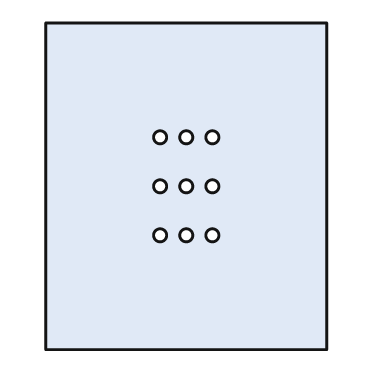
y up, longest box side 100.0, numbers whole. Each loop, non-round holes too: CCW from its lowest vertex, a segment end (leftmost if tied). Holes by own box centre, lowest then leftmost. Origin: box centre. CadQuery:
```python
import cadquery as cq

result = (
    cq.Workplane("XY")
    .moveTo(-43.0, -50.0)
    .lineTo(43.0, -50.0)
    .lineTo(43.0, 50.0)
    .lineTo(-43.0, 50.0)
    .close()
    .moveTo(-8.0, -15.0)
    .circle(2.0)
    .moveTo(0.0, -15.0)
    .circle(2.0)
    .moveTo(8.0, -15.0)
    .circle(2.0)
    .moveTo(-8.0, 0.0)
    .circle(2.0)
    .moveTo(0.0, 0.0)
    .circle(2.0)
    .moveTo(8.0, 0.0)
    .circle(2.0)
    .moveTo(-8.0, 15.0)
    .circle(2.0)
    .moveTo(0.0, 15.0)
    .circle(2.0)
    .moveTo(8.0, 15.0)
    .circle(2.0)
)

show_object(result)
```